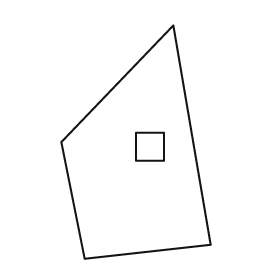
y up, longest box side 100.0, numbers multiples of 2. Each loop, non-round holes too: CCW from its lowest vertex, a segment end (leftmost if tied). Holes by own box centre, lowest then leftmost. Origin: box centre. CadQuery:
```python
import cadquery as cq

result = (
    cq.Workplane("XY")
    .moveTo(-22.0, -50.0)
    .lineTo(32.0, -44.0)
    .lineTo(16.0, 50.0)
    .lineTo(-32.0, 0.0)
    .close()
    .moveTo(0.0, -8.0)
    .lineTo(12.0, -8.0)
    .lineTo(12.0, 4.0)
    .lineTo(0.0, 4.0)
    .close()
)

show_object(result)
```